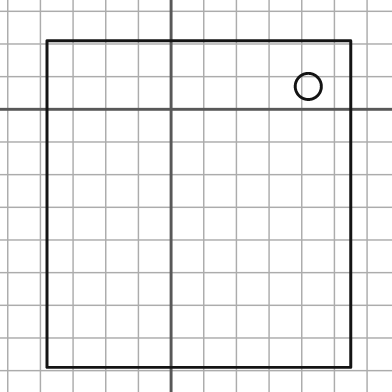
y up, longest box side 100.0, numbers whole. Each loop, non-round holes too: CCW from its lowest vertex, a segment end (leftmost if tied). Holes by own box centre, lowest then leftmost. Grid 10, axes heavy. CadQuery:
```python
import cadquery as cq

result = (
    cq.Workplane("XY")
    .moveTo(-38.0, -79.0)
    .lineTo(55.0, -79.0)
    .lineTo(55.0, 21.0)
    .lineTo(-38.0, 21.0)
    .close()
    .moveTo(42.0, 7.0)
    .circle(4.0)
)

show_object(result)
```